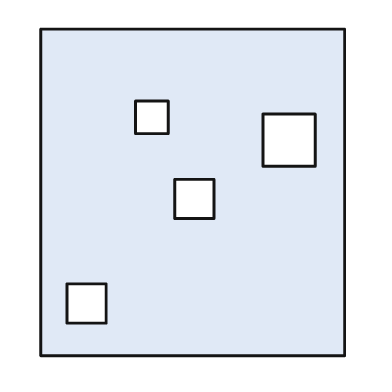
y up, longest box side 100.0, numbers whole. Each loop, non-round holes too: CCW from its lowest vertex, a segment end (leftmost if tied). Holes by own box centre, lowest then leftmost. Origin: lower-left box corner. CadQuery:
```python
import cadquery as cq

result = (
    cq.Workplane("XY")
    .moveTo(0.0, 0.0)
    .lineTo(93.0, 0.0)
    .lineTo(93.0, 100.0)
    .lineTo(0.0, 100.0)
    .close()
    .moveTo(8.0, 10.0)
    .lineTo(20.0, 10.0)
    .lineTo(20.0, 22.0)
    .lineTo(8.0, 22.0)
    .close()
    .moveTo(41.0, 42.0)
    .lineTo(53.0, 42.0)
    .lineTo(53.0, 54.0)
    .lineTo(41.0, 54.0)
    .close()
    .moveTo(68.0, 58.0)
    .lineTo(84.0, 58.0)
    .lineTo(84.0, 74.0)
    .lineTo(68.0, 74.0)
    .close()
    .moveTo(29.0, 68.0)
    .lineTo(39.0, 68.0)
    .lineTo(39.0, 78.0)
    .lineTo(29.0, 78.0)
    .close()
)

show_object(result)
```